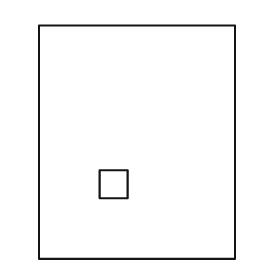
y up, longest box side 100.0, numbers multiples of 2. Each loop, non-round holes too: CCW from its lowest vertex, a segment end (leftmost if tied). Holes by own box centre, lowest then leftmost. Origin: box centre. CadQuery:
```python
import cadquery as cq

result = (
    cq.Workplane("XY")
    .moveTo(-42.0, -50.0)
    .lineTo(42.0, -50.0)
    .lineTo(42.0, 50.0)
    .lineTo(-42.0, 50.0)
    .close()
    .moveTo(-16.0, -24.0)
    .lineTo(-4.0, -24.0)
    .lineTo(-4.0, -12.0)
    .lineTo(-16.0, -12.0)
    .close()
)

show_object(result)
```